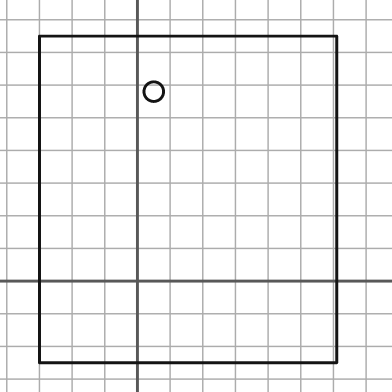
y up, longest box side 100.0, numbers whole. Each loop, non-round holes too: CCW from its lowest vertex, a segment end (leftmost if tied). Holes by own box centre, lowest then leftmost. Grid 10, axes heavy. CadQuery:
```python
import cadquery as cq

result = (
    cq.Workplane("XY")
    .moveTo(-30.0, -25.0)
    .lineTo(61.0, -25.0)
    .lineTo(61.0, 75.0)
    .lineTo(-30.0, 75.0)
    .close()
    .moveTo(5.0, 58.0)
    .circle(3.0)
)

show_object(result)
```